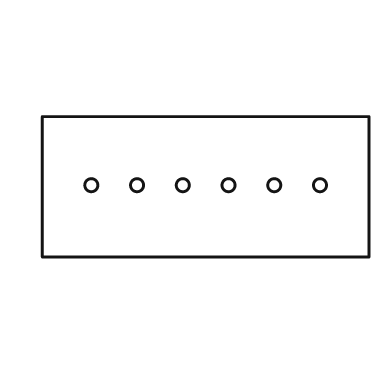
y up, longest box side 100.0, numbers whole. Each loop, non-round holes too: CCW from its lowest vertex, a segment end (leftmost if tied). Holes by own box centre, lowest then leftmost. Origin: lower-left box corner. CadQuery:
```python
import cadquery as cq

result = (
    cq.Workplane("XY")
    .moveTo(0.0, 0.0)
    .lineTo(100.0, 0.0)
    .lineTo(100.0, 43.0)
    .lineTo(0.0, 43.0)
    .close()
    .moveTo(15.0, 22.0)
    .circle(2.0)
    .moveTo(29.0, 22.0)
    .circle(2.0)
    .moveTo(43.0, 22.0)
    .circle(2.0)
    .moveTo(57.0, 22.0)
    .circle(2.0)
    .moveTo(71.0, 22.0)
    .circle(2.0)
    .moveTo(85.0, 22.0)
    .circle(2.0)
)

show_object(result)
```